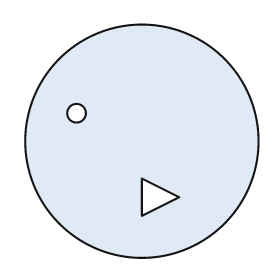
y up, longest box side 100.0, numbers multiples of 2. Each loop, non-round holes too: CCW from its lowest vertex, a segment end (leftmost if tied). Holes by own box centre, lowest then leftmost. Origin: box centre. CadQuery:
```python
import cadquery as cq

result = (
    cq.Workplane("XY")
    .moveTo(0.0, 0.0)
    .circle(50.0)
    .moveTo(0.0, -32.0)
    .lineTo(16.0, -24.0)
    .lineTo(0.0, -16.0)
    .close()
    .moveTo(-28.0, 12.0)
    .circle(4.0)
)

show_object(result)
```